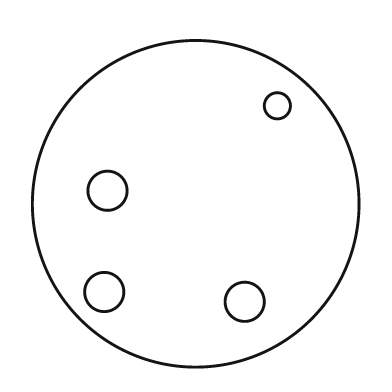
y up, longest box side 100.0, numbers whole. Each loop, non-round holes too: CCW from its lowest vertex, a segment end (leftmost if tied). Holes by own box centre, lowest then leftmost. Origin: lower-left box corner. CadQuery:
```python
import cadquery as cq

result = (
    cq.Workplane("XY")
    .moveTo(50.0, 50.0)
    .circle(50.0)
    .moveTo(65.0, 20.0)
    .circle(6.0)
    .moveTo(22.0, 23.0)
    .circle(6.0)
    .moveTo(23.0, 54.0)
    .circle(6.0)
    .moveTo(75.0, 80.0)
    .circle(4.0)
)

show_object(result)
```